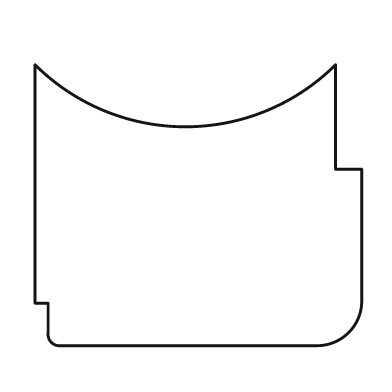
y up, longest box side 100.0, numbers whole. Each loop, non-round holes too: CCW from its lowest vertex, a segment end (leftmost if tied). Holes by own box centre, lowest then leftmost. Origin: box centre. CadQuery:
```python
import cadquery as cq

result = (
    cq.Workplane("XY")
    .moveTo(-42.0, -43.0)
    .lineTo(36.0, -43.0)
    .threePointArc((46.0, -39.0), (50.0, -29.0))
    .lineTo(50.0, 11.0)
    .lineTo(42.0, 11.0)
    .lineTo(42.0, 43.0)
    .threePointArc((-4.0, 24.0), (-50.0, 43.0))
    .lineTo(-50.0, -30.0)
    .lineTo(-46.0, -30.0)
    .lineTo(-46.0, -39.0)
    .threePointArc((-45.0, -42.0), (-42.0, -43.0))
    .close()
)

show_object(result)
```